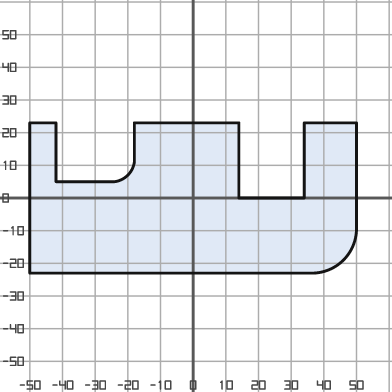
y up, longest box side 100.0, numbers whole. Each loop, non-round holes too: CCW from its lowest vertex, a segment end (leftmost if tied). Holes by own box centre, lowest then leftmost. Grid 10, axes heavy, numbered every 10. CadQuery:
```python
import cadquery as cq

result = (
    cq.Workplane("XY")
    .moveTo(-50.0, -23.0)
    .lineTo(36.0, -23.0)
    .threePointArc((46.0, -19.0), (50.0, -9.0))
    .lineTo(50.0, 23.0)
    .lineTo(34.0, 23.0)
    .lineTo(34.0, 0.0)
    .lineTo(14.0, 0.0)
    .lineTo(14.0, 23.0)
    .lineTo(-18.0, 23.0)
    .lineTo(-18.0, 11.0)
    .threePointArc((-20.0, 7.0), (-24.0, 5.0))
    .lineTo(-42.0, 5.0)
    .lineTo(-42.0, 23.0)
    .lineTo(-50.0, 23.0)
    .close()
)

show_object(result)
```